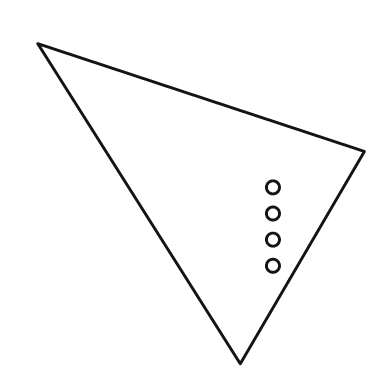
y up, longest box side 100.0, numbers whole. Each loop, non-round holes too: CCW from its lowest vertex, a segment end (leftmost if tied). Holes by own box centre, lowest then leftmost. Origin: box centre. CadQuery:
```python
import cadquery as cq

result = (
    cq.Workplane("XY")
    .moveTo(12.0, -49.0)
    .lineTo(50.0, 16.0)
    .lineTo(-50.0, 49.0)
    .close()
    .moveTo(22.0, -19.0)
    .circle(2.0)
    .moveTo(22.0, -11.0)
    .circle(2.0)
    .moveTo(22.0, -3.0)
    .circle(2.0)
    .moveTo(22.0, 5.0)
    .circle(2.0)
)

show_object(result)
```